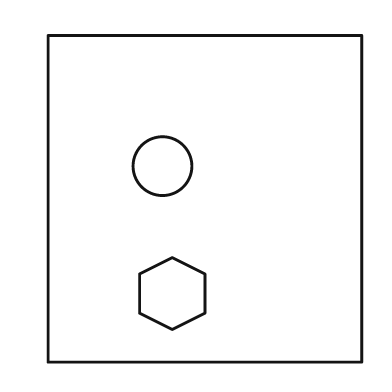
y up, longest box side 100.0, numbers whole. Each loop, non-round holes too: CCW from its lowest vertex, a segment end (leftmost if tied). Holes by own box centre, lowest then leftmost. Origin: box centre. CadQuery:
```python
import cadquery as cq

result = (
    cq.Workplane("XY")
    .moveTo(-48.0, -50.0)
    .lineTo(48.0, -50.0)
    .lineTo(48.0, 50.0)
    .lineTo(-48.0, 50.0)
    .close()
    .moveTo(-10.0, -40.0)
    .lineTo(0.0, -35.0)
    .lineTo(0.0, -23.0)
    .lineTo(-10.0, -18.0)
    .lineTo(-20.0, -23.0)
    .lineTo(-20.0, -35.0)
    .close()
    .moveTo(-13.0, 10.0)
    .circle(9.0)
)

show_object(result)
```